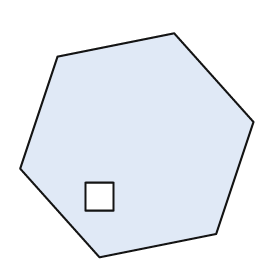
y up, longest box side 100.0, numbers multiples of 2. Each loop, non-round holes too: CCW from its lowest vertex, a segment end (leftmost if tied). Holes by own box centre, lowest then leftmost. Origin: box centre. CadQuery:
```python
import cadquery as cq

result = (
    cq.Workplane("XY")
    .moveTo(-16.0, -48.0)
    .lineTo(34.0, -38.0)
    .lineTo(50.0, 10.0)
    .lineTo(16.0, 48.0)
    .lineTo(-34.0, 38.0)
    .lineTo(-50.0, -10.0)
    .close()
    .moveTo(-22.0, -28.0)
    .lineTo(-10.0, -28.0)
    .lineTo(-10.0, -16.0)
    .lineTo(-22.0, -16.0)
    .close()
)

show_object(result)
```